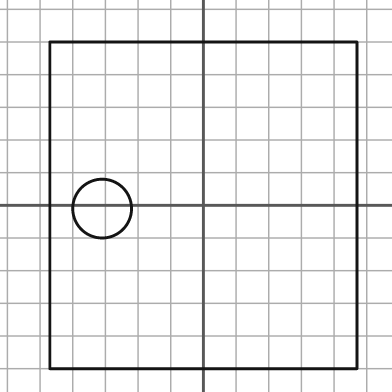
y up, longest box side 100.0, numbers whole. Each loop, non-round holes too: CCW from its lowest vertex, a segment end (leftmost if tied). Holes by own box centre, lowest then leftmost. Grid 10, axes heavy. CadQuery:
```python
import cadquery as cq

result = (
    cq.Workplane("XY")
    .moveTo(-47.0, -50.0)
    .lineTo(47.0, -50.0)
    .lineTo(47.0, 50.0)
    .lineTo(-47.0, 50.0)
    .close()
    .moveTo(-31.0, -1.0)
    .circle(9.0)
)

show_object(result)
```